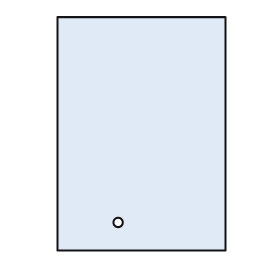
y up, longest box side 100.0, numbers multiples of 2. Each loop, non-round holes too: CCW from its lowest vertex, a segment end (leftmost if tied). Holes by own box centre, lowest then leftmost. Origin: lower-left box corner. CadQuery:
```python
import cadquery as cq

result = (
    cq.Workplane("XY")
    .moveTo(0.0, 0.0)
    .lineTo(72.0, 0.0)
    .lineTo(72.0, 100.0)
    .lineTo(0.0, 100.0)
    .close()
    .moveTo(26.0, 12.0)
    .circle(2.0)
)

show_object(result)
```